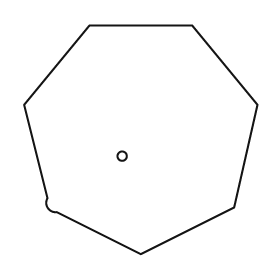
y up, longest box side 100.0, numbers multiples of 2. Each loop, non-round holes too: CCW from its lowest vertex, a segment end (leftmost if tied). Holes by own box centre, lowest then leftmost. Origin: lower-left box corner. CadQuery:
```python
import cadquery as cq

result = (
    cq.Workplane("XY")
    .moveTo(50.0, 0.0)
    .lineTo(90.0, 20.0)
    .lineTo(100.0, 64.0)
    .lineTo(72.0, 98.0)
    .lineTo(28.0, 98.0)
    .lineTo(0.0, 64.0)
    .lineTo(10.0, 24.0)
    .threePointArc((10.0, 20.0), (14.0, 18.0))
    .close()
    .moveTo(42.0, 42.0)
    .circle(2.0)
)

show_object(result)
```